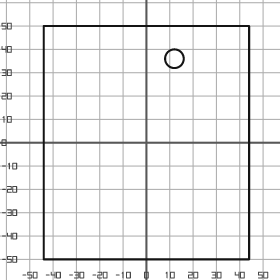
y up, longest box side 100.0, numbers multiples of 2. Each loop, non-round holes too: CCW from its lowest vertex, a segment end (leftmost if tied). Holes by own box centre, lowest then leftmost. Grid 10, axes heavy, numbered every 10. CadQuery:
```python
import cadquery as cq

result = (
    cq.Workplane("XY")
    .moveTo(-44.0, -50.0)
    .lineTo(44.0, -50.0)
    .lineTo(44.0, 50.0)
    .lineTo(-44.0, 50.0)
    .close()
    .moveTo(12.0, 36.0)
    .circle(4.0)
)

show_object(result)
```